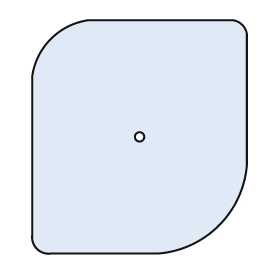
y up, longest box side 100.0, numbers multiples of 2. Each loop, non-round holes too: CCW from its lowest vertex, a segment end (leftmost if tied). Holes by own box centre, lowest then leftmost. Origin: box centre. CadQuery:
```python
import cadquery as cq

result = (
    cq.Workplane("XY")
    .moveTo(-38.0, -50.0)
    .lineTo(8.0, -50.0)
    .threePointArc((34.0, -38.0), (46.0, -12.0))
    .lineTo(46.0, 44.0)
    .threePointArc((44.0, 48.0), (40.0, 50.0))
    .lineTo(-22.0, 50.0)
    .threePointArc((-38.0, 42.0), (-46.0, 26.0))
    .lineTo(-46.0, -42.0)
    .threePointArc((-44.0, -48.0), (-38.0, -50.0))
    .close()
    .moveTo(0.0, 0.0)
    .circle(2.0)
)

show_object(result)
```